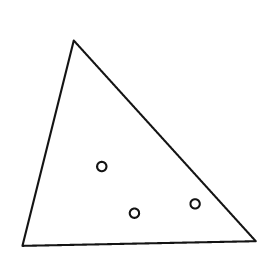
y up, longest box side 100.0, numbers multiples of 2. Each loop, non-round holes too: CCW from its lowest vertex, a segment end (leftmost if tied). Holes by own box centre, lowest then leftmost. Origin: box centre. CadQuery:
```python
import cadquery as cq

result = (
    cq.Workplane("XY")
    .moveTo(-50.0, -44.0)
    .lineTo(50.0, -42.0)
    .lineTo(-28.0, 44.0)
    .close()
    .moveTo(-2.0, -30.0)
    .circle(2.0)
    .moveTo(24.0, -26.0)
    .circle(2.0)
    .moveTo(-16.0, -10.0)
    .circle(2.0)
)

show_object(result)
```